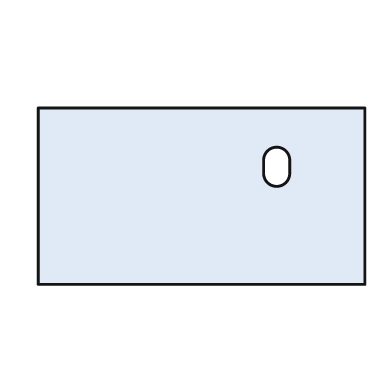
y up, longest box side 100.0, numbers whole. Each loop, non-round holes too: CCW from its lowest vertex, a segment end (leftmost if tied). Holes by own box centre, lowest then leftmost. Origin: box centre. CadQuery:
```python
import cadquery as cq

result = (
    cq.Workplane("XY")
    .moveTo(-50.0, -27.0)
    .lineTo(50.0, -27.0)
    .lineTo(50.0, 27.0)
    .lineTo(-50.0, 27.0)
    .close()
    .moveTo(19.0, 7.0)
    .threePointArc((23.0, 3.0), (27.0, 7.0))
    .lineTo(27.0, 11.0)
    .threePointArc((23.0, 15.0), (19.0, 11.0))
    .close()
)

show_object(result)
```